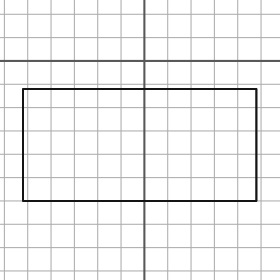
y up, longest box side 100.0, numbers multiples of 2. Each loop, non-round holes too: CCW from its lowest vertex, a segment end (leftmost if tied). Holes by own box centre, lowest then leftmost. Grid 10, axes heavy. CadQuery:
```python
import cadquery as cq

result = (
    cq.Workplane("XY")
    .moveTo(-52.0, -60.0)
    .lineTo(48.0, -60.0)
    .lineTo(48.0, -12.0)
    .lineTo(-52.0, -12.0)
    .close()
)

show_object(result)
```